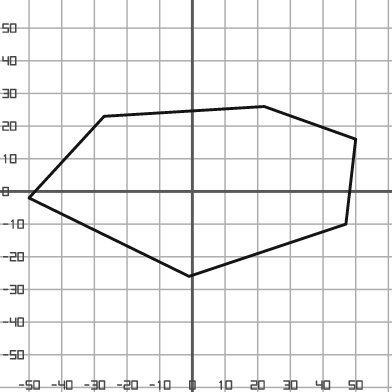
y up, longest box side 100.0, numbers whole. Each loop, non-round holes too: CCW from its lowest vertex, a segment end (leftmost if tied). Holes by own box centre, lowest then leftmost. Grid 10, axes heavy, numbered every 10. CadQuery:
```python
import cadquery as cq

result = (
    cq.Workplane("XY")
    .moveTo(-1.0, -26.0)
    .lineTo(47.0, -10.0)
    .lineTo(50.0, 16.0)
    .lineTo(22.0, 26.0)
    .lineTo(-27.0, 23.0)
    .lineTo(-50.0, -2.0)
    .close()
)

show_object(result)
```